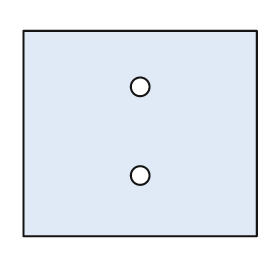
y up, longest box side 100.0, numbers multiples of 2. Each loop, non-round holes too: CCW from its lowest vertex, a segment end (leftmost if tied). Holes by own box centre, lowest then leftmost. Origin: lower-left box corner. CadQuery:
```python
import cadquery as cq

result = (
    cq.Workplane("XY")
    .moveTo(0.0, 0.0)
    .lineTo(100.0, 0.0)
    .lineTo(100.0, 88.0)
    .lineTo(0.0, 88.0)
    .close()
    .moveTo(50.0, 26.0)
    .circle(4.0)
    .moveTo(50.0, 64.0)
    .circle(4.0)
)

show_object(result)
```